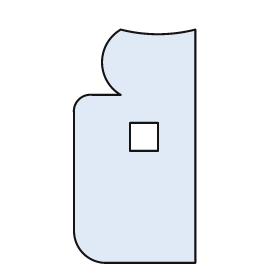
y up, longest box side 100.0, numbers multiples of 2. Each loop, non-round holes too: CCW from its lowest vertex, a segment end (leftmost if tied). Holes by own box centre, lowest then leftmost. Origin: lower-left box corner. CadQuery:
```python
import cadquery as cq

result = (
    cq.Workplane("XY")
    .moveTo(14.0, 0.0)
    .lineTo(52.0, 0.0)
    .lineTo(52.0, 100.0)
    .threePointArc((36.0, 98.0), (20.0, 100.0))
    .threePointArc((12.0, 86.0), (20.0, 72.0))
    .lineTo(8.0, 72.0)
    .threePointArc((2.0, 70.0), (0.0, 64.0))
    .lineTo(0.0, 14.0)
    .threePointArc((4.0, 4.0), (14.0, 0.0))
    .close()
    .moveTo(24.0, 48.0)
    .lineTo(36.0, 48.0)
    .lineTo(36.0, 60.0)
    .lineTo(24.0, 60.0)
    .close()
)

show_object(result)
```